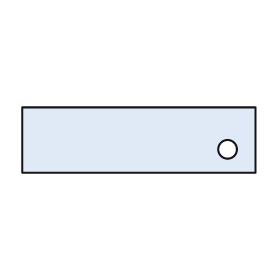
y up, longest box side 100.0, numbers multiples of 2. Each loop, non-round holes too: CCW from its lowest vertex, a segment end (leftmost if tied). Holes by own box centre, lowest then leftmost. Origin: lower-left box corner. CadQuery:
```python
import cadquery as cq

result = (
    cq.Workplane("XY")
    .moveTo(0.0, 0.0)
    .lineTo(100.0, 0.0)
    .lineTo(100.0, 28.0)
    .lineTo(0.0, 28.0)
    .close()
    .moveTo(88.0, 10.0)
    .circle(4.0)
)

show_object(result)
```